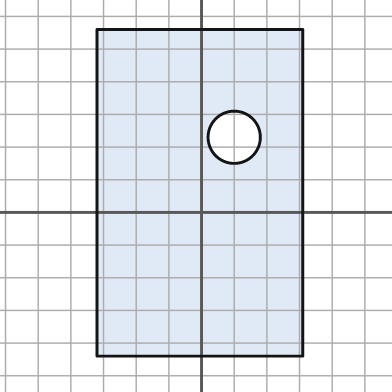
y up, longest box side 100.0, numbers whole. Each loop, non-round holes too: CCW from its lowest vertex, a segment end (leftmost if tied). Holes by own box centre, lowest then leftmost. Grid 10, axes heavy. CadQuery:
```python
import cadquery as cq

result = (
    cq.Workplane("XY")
    .moveTo(-32.0, -44.0)
    .lineTo(31.0, -44.0)
    .lineTo(31.0, 56.0)
    .lineTo(-32.0, 56.0)
    .close()
    .moveTo(10.0, 23.0)
    .circle(8.0)
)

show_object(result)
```